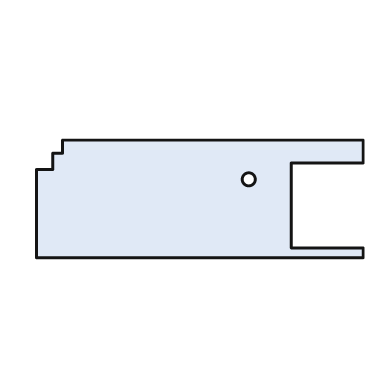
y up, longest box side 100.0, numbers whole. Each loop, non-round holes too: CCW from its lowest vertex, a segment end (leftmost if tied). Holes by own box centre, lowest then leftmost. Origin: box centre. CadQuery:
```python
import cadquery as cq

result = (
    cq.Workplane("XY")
    .moveTo(-50.0, -18.0)
    .lineTo(50.0, -18.0)
    .lineTo(50.0, -15.0)
    .lineTo(28.0, -15.0)
    .lineTo(28.0, 11.0)
    .lineTo(50.0, 11.0)
    .lineTo(50.0, 18.0)
    .lineTo(-42.0, 18.0)
    .lineTo(-42.0, 14.0)
    .lineTo(-45.0, 14.0)
    .lineTo(-45.0, 9.0)
    .lineTo(-50.0, 9.0)
    .close()
    .moveTo(15.0, 6.0)
    .circle(2.0)
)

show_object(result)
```